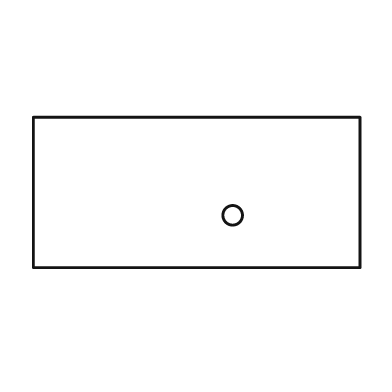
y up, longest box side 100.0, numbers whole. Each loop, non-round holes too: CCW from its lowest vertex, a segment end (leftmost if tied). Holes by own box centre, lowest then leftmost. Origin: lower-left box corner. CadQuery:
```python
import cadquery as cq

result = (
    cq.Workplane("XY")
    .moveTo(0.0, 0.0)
    .lineTo(100.0, 0.0)
    .lineTo(100.0, 46.0)
    .lineTo(0.0, 46.0)
    .close()
    .moveTo(61.0, 16.0)
    .circle(3.0)
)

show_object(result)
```